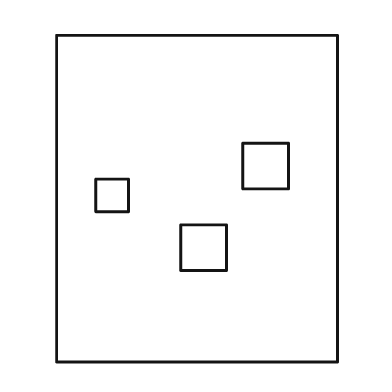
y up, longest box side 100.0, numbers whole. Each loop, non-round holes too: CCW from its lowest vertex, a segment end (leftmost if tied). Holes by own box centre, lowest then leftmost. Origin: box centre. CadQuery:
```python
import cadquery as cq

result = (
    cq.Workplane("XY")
    .moveTo(-43.0, -50.0)
    .lineTo(43.0, -50.0)
    .lineTo(43.0, 50.0)
    .lineTo(-43.0, 50.0)
    .close()
    .moveTo(-5.0, -22.0)
    .lineTo(9.0, -22.0)
    .lineTo(9.0, -8.0)
    .lineTo(-5.0, -8.0)
    .close()
    .moveTo(-31.0, -4.0)
    .lineTo(-21.0, -4.0)
    .lineTo(-21.0, 6.0)
    .lineTo(-31.0, 6.0)
    .close()
    .moveTo(14.0, 3.0)
    .lineTo(28.0, 3.0)
    .lineTo(28.0, 17.0)
    .lineTo(14.0, 17.0)
    .close()
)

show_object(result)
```